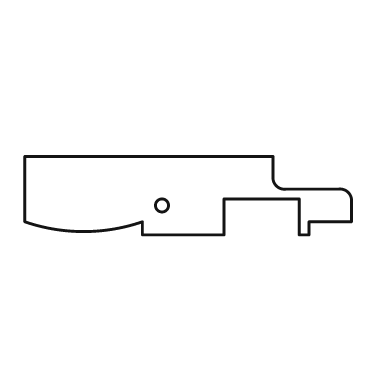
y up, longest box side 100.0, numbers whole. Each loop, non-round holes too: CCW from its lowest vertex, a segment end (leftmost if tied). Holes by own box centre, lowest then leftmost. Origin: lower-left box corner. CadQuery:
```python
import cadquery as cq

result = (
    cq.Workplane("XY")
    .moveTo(36.0, 0.0)
    .lineTo(61.0, 0.0)
    .lineTo(61.0, 11.0)
    .lineTo(84.0, 11.0)
    .lineTo(84.0, 0.0)
    .lineTo(87.0, 0.0)
    .lineTo(87.0, 4.0)
    .lineTo(100.0, 4.0)
    .lineTo(100.0, 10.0)
    .threePointArc((99.0, 13.0), (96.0, 14.0))
    .lineTo(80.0, 14.0)
    .threePointArc((77.0, 15.0), (76.0, 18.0))
    .lineTo(76.0, 24.0)
    .lineTo(0.0, 24.0)
    .lineTo(0.0, 4.0)
    .threePointArc((18.0, 1.0), (36.0, 4.0))
    .close()
    .moveTo(42.0, 9.0)
    .circle(2.0)
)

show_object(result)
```